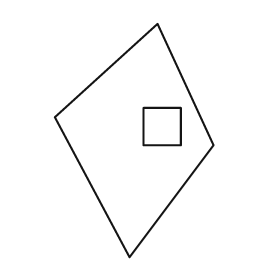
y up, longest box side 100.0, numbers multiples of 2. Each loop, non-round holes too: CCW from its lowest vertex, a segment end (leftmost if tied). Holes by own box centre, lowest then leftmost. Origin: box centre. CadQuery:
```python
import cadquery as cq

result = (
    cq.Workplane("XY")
    .moveTo(-2.0, -50.0)
    .lineTo(34.0, -2.0)
    .lineTo(10.0, 50.0)
    .lineTo(-34.0, 10.0)
    .close()
    .moveTo(4.0, -2.0)
    .lineTo(20.0, -2.0)
    .lineTo(20.0, 14.0)
    .lineTo(4.0, 14.0)
    .close()
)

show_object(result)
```